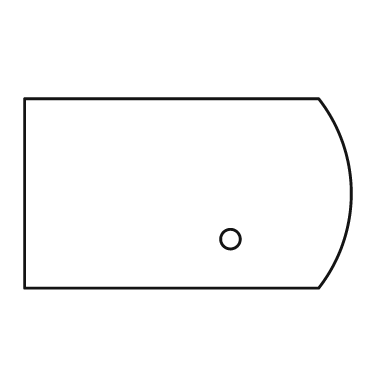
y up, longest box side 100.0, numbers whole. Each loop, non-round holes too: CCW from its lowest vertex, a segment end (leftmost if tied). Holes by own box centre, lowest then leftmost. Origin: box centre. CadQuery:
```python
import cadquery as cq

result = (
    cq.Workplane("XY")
    .moveTo(-50.0, -29.0)
    .lineTo(40.0, -29.0)
    .threePointArc((50.0, 0.0), (40.0, 29.0))
    .lineTo(-50.0, 29.0)
    .close()
    .moveTo(13.0, -14.0)
    .circle(3.0)
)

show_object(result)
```